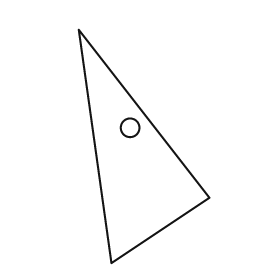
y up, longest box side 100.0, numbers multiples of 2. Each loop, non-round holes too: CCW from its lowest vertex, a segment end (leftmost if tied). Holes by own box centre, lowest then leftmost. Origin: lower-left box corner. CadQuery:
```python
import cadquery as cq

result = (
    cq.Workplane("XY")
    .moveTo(14.0, 0.0)
    .lineTo(56.0, 28.0)
    .lineTo(0.0, 100.0)
    .close()
    .moveTo(22.0, 58.0)
    .circle(4.0)
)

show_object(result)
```